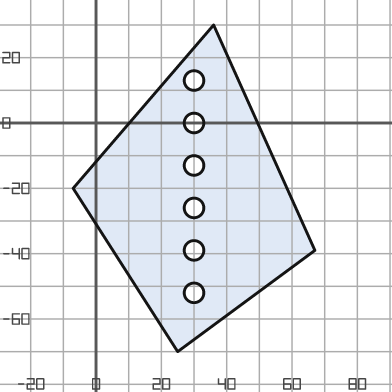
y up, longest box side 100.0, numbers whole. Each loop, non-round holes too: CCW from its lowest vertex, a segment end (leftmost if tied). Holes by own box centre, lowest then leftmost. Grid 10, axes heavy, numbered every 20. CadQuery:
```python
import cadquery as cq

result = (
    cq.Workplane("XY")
    .moveTo(25.0, -70.0)
    .lineTo(67.0, -39.0)
    .lineTo(36.0, 30.0)
    .lineTo(-7.0, -20.0)
    .close()
    .moveTo(30.0, -52.0)
    .circle(3.0)
    .moveTo(30.0, -39.0)
    .circle(3.0)
    .moveTo(30.0, -26.0)
    .circle(3.0)
    .moveTo(30.0, -13.0)
    .circle(3.0)
    .moveTo(30.0, 0.0)
    .circle(3.0)
    .moveTo(30.0, 13.0)
    .circle(3.0)
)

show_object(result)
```